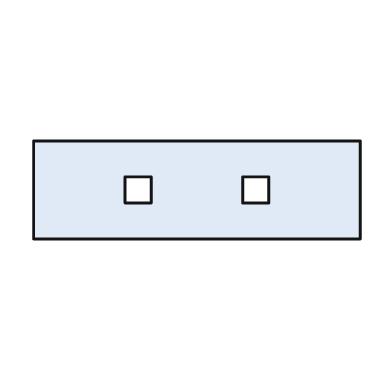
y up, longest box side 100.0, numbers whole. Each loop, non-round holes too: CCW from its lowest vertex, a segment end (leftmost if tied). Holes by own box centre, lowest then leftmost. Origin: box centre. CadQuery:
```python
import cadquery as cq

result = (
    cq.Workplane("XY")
    .moveTo(-50.0, -15.0)
    .lineTo(50.0, -15.0)
    .lineTo(50.0, 15.0)
    .lineTo(-50.0, 15.0)
    .close()
    .moveTo(-22.0, -4.0)
    .lineTo(-14.0, -4.0)
    .lineTo(-14.0, 4.0)
    .lineTo(-22.0, 4.0)
    .close()
    .moveTo(14.0, -4.0)
    .lineTo(22.0, -4.0)
    .lineTo(22.0, 4.0)
    .lineTo(14.0, 4.0)
    .close()
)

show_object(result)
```